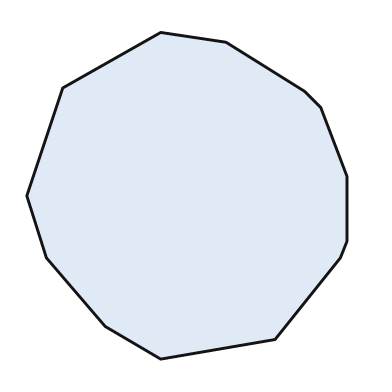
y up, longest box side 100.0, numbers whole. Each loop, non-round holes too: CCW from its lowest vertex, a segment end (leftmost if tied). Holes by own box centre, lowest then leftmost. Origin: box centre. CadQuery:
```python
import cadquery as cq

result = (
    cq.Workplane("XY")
    .moveTo(-8.0, -50.0)
    .lineTo(27.0, -44.0)
    .lineTo(47.0, -19.0)
    .lineTo(49.0, -14.0)
    .lineTo(49.0, 6.0)
    .lineTo(41.0, 27.0)
    .lineTo(36.0, 32.0)
    .lineTo(12.0, 47.0)
    .lineTo(-8.0, 50.0)
    .lineTo(-38.0, 33.0)
    .lineTo(-49.0, 0.0)
    .lineTo(-43.0, -19.0)
    .lineTo(-25.0, -40.0)
    .close()
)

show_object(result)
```